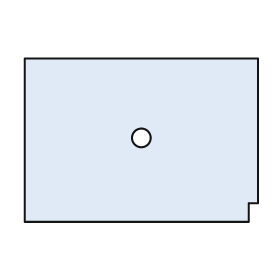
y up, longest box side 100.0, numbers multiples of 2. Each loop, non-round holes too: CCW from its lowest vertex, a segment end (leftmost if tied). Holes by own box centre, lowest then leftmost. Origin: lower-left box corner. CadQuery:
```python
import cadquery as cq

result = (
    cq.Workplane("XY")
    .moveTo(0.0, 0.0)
    .lineTo(96.0, 0.0)
    .lineTo(96.0, 8.0)
    .lineTo(100.0, 8.0)
    .lineTo(100.0, 70.0)
    .lineTo(0.0, 70.0)
    .close()
    .moveTo(50.0, 36.0)
    .circle(4.0)
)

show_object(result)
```